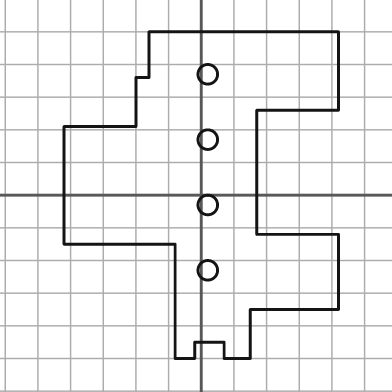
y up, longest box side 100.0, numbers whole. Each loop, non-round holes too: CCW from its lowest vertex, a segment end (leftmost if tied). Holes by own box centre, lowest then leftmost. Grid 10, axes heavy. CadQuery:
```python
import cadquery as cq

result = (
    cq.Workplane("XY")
    .moveTo(-8.0, -50.0)
    .lineTo(-2.0, -50.0)
    .lineTo(-2.0, -45.0)
    .lineTo(7.0, -45.0)
    .lineTo(7.0, -50.0)
    .lineTo(15.0, -50.0)
    .lineTo(15.0, -35.0)
    .lineTo(42.0, -35.0)
    .lineTo(42.0, -12.0)
    .lineTo(17.0, -12.0)
    .lineTo(17.0, 26.0)
    .lineTo(42.0, 26.0)
    .lineTo(42.0, 50.0)
    .lineTo(-16.0, 50.0)
    .lineTo(-16.0, 36.0)
    .lineTo(-20.0, 36.0)
    .lineTo(-20.0, 21.0)
    .lineTo(-42.0, 21.0)
    .lineTo(-42.0, -15.0)
    .lineTo(-8.0, -15.0)
    .close()
    .moveTo(2.0, -23.0)
    .circle(3.0)
    .moveTo(2.0, -3.0)
    .circle(3.0)
    .moveTo(2.0, 17.0)
    .circle(3.0)
    .moveTo(2.0, 37.0)
    .circle(3.0)
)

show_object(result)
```